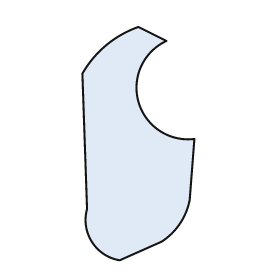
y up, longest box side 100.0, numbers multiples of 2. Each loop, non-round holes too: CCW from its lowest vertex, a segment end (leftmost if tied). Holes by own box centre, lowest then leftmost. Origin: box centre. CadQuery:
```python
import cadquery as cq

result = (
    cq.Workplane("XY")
    .moveTo(-8.0, -50.0)
    .lineTo(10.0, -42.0)
    .threePointArc((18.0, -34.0), (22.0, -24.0))
    .lineTo(24.0, 2.0)
    .threePointArc((0.0, 18.0), (12.0, 44.0))
    .lineTo(0.0, 50.0)
    .threePointArc((-14.0, 42.0), (-24.0, 30.0))
    .lineTo(-22.0, -28.0)
    .threePointArc((-20.0, -42.0), (-8.0, -50.0))
    .close()
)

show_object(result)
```